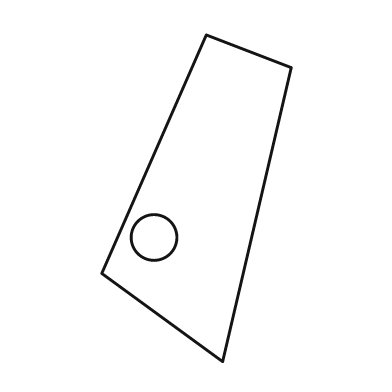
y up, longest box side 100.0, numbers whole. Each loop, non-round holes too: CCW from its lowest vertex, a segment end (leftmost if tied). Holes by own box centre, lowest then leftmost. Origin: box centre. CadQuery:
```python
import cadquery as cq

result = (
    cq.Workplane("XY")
    .moveTo(8.0, -50.0)
    .lineTo(29.0, 40.0)
    .lineTo(3.0, 50.0)
    .lineTo(-29.0, -23.0)
    .close()
    .moveTo(-13.0, -12.0)
    .circle(7.0)
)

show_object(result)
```